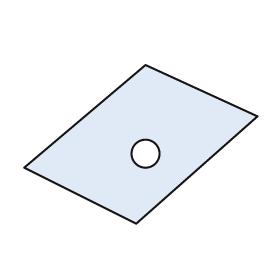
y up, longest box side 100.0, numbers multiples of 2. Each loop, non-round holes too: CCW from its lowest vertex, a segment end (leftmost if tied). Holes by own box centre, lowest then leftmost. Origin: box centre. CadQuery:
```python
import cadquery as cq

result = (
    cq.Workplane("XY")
    .moveTo(-2.0, -34.0)
    .lineTo(50.0, 12.0)
    .lineTo(2.0, 34.0)
    .lineTo(-50.0, -10.0)
    .close()
    .moveTo(2.0, -4.0)
    .circle(6.0)
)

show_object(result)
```